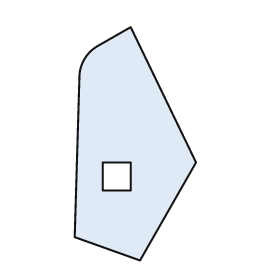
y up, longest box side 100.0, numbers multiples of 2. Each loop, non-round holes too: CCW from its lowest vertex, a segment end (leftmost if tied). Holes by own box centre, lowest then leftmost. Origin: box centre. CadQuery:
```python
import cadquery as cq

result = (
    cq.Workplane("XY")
    .moveTo(2.0, -50.0)
    .lineTo(26.0, -8.0)
    .lineTo(-2.0, 50.0)
    .lineTo(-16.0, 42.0)
    .threePointArc((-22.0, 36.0), (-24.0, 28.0))
    .lineTo(-26.0, -40.0)
    .close()
    .moveTo(-14.0, -20.0)
    .lineTo(-2.0, -20.0)
    .lineTo(-2.0, -8.0)
    .lineTo(-14.0, -8.0)
    .close()
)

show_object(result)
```